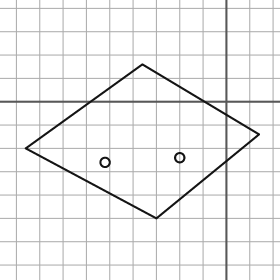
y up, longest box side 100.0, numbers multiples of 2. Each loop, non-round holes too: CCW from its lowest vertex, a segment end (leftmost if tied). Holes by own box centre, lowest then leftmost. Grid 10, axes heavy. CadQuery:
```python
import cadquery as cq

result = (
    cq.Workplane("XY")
    .moveTo(-30.0, -50.0)
    .lineTo(14.0, -14.0)
    .lineTo(-36.0, 16.0)
    .lineTo(-86.0, -20.0)
    .close()
    .moveTo(-52.0, -26.0)
    .circle(2.0)
    .moveTo(-20.0, -24.0)
    .circle(2.0)
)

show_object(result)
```